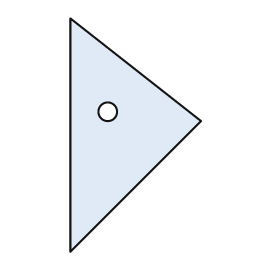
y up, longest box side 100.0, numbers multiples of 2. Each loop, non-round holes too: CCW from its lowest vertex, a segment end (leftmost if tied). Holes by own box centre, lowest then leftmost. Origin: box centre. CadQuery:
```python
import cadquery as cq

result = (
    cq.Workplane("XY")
    .moveTo(-28.0, -50.0)
    .lineTo(28.0, 6.0)
    .lineTo(-28.0, 50.0)
    .close()
    .moveTo(-12.0, 10.0)
    .circle(4.0)
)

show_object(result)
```